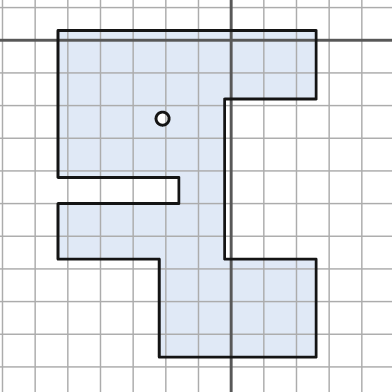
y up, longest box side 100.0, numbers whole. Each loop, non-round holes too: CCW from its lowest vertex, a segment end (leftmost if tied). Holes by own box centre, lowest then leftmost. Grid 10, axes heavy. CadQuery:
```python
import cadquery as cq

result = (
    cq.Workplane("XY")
    .moveTo(-22.0, -97.0)
    .lineTo(26.0, -97.0)
    .lineTo(26.0, -67.0)
    .lineTo(-2.0, -67.0)
    .lineTo(-2.0, -18.0)
    .lineTo(26.0, -18.0)
    .lineTo(26.0, 3.0)
    .lineTo(-53.0, 3.0)
    .lineTo(-53.0, -42.0)
    .lineTo(-16.0, -42.0)
    .lineTo(-16.0, -50.0)
    .lineTo(-53.0, -50.0)
    .lineTo(-53.0, -67.0)
    .lineTo(-22.0, -67.0)
    .close()
    .moveTo(-21.0, -24.0)
    .circle(2.0)
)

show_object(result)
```